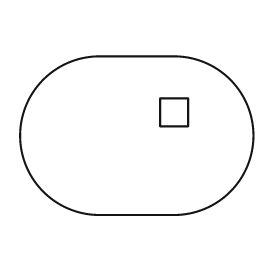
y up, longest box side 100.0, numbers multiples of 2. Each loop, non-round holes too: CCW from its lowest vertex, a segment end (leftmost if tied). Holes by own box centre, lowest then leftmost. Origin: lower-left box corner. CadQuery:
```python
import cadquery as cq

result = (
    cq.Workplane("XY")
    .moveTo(34.0, 0.0)
    .lineTo(66.0, 0.0)
    .threePointArc((100.0, 34.0), (66.0, 68.0))
    .lineTo(34.0, 68.0)
    .threePointArc((0.0, 34.0), (34.0, 0.0))
    .close()
    .moveTo(60.0, 38.0)
    .lineTo(72.0, 38.0)
    .lineTo(72.0, 50.0)
    .lineTo(60.0, 50.0)
    .close()
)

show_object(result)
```